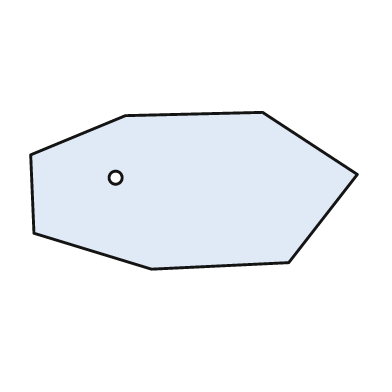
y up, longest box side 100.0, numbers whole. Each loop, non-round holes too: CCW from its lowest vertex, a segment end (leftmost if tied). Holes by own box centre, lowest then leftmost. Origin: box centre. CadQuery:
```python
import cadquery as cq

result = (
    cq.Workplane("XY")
    .moveTo(-13.0, -24.0)
    .lineTo(29.0, -22.0)
    .lineTo(50.0, 5.0)
    .lineTo(21.0, 24.0)
    .lineTo(-21.0, 23.0)
    .lineTo(-50.0, 11.0)
    .lineTo(-49.0, -13.0)
    .close()
    .moveTo(-24.0, 4.0)
    .circle(2.0)
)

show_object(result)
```